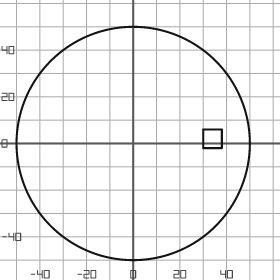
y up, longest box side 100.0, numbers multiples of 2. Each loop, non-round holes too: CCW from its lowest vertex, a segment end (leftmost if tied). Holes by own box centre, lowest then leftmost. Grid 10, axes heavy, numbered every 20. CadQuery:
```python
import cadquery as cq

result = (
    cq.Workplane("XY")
    .moveTo(0.0, 0.0)
    .circle(50.0)
    .moveTo(30.0, -2.0)
    .lineTo(38.0, -2.0)
    .lineTo(38.0, 6.0)
    .lineTo(30.0, 6.0)
    .close()
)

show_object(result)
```